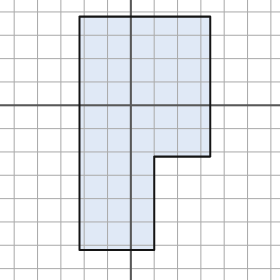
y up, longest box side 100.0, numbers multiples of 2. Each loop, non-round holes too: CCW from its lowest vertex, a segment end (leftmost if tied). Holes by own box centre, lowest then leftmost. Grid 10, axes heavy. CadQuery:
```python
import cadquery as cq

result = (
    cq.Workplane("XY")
    .moveTo(-22.0, -62.0)
    .lineTo(10.0, -62.0)
    .lineTo(10.0, -22.0)
    .lineTo(34.0, -22.0)
    .lineTo(34.0, 38.0)
    .lineTo(-22.0, 38.0)
    .close()
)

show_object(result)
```